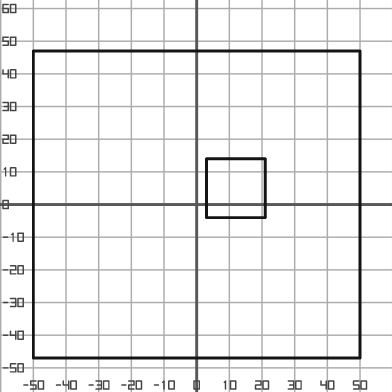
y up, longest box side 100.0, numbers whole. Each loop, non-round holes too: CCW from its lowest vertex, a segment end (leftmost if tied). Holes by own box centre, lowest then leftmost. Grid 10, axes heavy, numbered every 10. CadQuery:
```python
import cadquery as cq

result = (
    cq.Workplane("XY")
    .moveTo(-50.0, -47.0)
    .lineTo(50.0, -47.0)
    .lineTo(50.0, 47.0)
    .lineTo(-50.0, 47.0)
    .close()
    .moveTo(3.0, -4.0)
    .lineTo(21.0, -4.0)
    .lineTo(21.0, 14.0)
    .lineTo(3.0, 14.0)
    .close()
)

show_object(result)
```